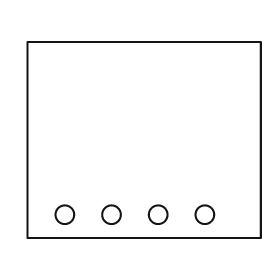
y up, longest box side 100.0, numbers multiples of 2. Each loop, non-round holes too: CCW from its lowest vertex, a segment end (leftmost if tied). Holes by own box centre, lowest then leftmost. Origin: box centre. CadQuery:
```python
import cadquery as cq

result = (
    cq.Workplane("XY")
    .moveTo(-50.0, -42.0)
    .lineTo(50.0, -42.0)
    .lineTo(50.0, 42.0)
    .lineTo(-50.0, 42.0)
    .close()
    .moveTo(-34.0, -32.0)
    .circle(4.0)
    .moveTo(-14.0, -32.0)
    .circle(4.0)
    .moveTo(6.0, -32.0)
    .circle(4.0)
    .moveTo(26.0, -32.0)
    .circle(4.0)
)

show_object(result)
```